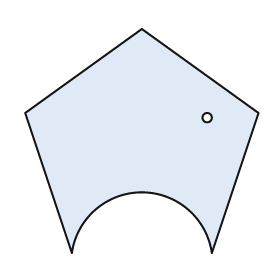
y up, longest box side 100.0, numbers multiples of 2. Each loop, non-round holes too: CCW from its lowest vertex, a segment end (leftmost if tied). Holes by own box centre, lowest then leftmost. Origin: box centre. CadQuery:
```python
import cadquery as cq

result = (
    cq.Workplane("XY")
    .moveTo(-30.0, -48.0)
    .threePointArc((0.0, -22.0), (30.0, -48.0))
    .lineTo(50.0, 12.0)
    .lineTo(0.0, 48.0)
    .lineTo(-50.0, 12.0)
    .close()
    .moveTo(28.0, 10.0)
    .circle(2.0)
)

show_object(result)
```